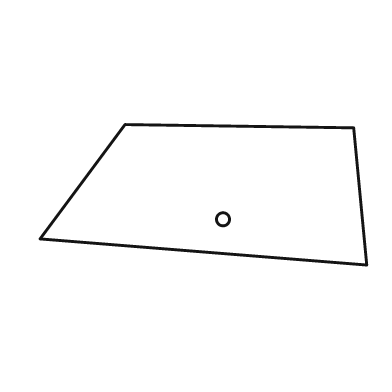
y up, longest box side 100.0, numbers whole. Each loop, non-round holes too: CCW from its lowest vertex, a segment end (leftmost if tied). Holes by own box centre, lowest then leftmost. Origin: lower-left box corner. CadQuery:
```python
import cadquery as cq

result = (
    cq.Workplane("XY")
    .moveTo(100.0, 0.0)
    .lineTo(96.0, 42.0)
    .lineTo(26.0, 43.0)
    .lineTo(0.0, 8.0)
    .close()
    .moveTo(56.0, 14.0)
    .circle(2.0)
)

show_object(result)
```